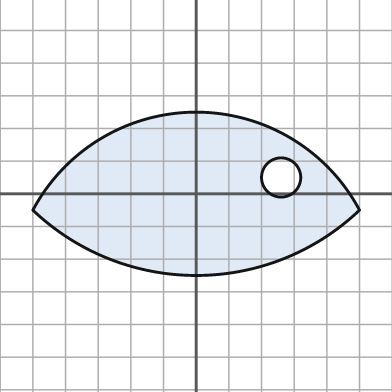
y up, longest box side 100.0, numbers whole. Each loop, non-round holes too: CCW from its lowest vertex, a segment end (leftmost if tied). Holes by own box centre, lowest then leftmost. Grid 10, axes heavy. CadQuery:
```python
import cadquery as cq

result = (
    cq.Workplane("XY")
    .moveTo(-50.0, -5.0)
    .threePointArc((0.0, -25.0), (50.0, -5.0))
    .threePointArc((0.0, 25.0), (-50.0, -5.0))
    .close()
    .moveTo(26.0, 5.0)
    .circle(6.0)
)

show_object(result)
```